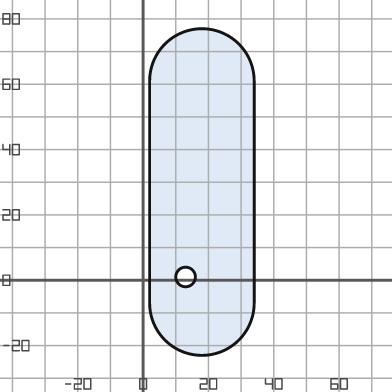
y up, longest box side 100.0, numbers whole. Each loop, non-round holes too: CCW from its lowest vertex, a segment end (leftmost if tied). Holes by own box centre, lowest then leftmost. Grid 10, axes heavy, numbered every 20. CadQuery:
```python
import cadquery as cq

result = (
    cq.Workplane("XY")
    .moveTo(2.0, -7.0)
    .threePointArc((18.0, -23.0), (34.0, -7.0))
    .lineTo(34.0, 61.0)
    .threePointArc((18.0, 77.0), (2.0, 61.0))
    .close()
    .moveTo(13.0, 1.0)
    .circle(3.0)
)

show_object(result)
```